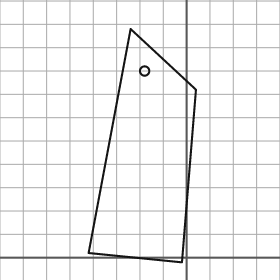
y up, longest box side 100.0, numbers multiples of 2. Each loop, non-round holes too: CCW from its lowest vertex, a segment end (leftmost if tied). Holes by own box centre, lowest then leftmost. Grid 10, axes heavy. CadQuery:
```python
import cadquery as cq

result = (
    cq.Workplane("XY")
    .moveTo(-2.0, -2.0)
    .lineTo(4.0, 72.0)
    .lineTo(-24.0, 98.0)
    .lineTo(-42.0, 2.0)
    .close()
    .moveTo(-18.0, 80.0)
    .circle(2.0)
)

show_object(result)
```